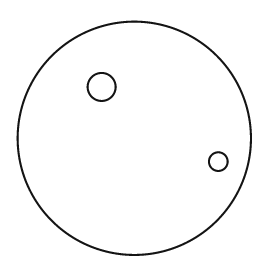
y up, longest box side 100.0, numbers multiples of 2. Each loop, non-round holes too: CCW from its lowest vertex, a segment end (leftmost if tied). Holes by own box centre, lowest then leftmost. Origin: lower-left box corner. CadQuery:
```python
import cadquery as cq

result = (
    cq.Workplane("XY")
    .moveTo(50.0, 50.0)
    .circle(50.0)
    .moveTo(86.0, 40.0)
    .circle(4.0)
    .moveTo(36.0, 72.0)
    .circle(6.0)
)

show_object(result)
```